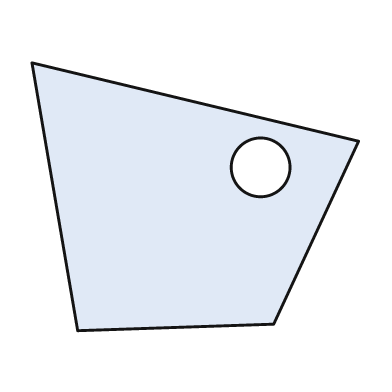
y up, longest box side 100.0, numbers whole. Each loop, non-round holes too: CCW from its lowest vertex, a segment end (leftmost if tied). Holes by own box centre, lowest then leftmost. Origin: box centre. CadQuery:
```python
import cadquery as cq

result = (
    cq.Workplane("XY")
    .moveTo(-36.0, -41.0)
    .lineTo(24.0, -39.0)
    .lineTo(50.0, 17.0)
    .lineTo(-50.0, 41.0)
    .close()
    .moveTo(20.0, 9.0)
    .circle(9.0)
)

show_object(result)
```